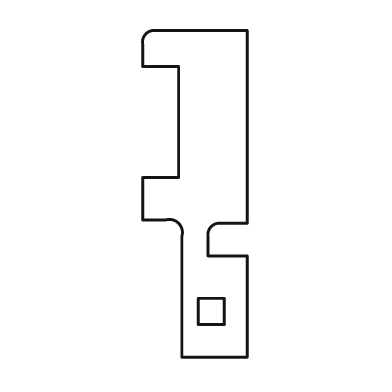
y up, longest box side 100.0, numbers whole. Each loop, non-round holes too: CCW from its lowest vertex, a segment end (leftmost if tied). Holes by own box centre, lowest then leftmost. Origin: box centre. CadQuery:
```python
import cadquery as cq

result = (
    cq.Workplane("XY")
    .moveTo(-4.0, -50.0)
    .lineTo(16.0, -50.0)
    .lineTo(16.0, -19.0)
    .lineTo(4.0, -19.0)
    .lineTo(4.0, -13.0)
    .threePointArc((5.0, -10.0), (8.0, -9.0))
    .lineTo(16.0, -9.0)
    .lineTo(16.0, 50.0)
    .lineTo(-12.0, 50.0)
    .threePointArc((-15.0, 49.0), (-16.0, 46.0))
    .lineTo(-16.0, 39.0)
    .lineTo(-5.0, 39.0)
    .lineTo(-5.0, 5.0)
    .lineTo(-16.0, 5.0)
    .lineTo(-16.0, -8.0)
    .lineTo(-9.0, -8.0)
    .threePointArc((-5.0, -9.0), (-4.0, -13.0))
    .close()
    .moveTo(1.0, -40.0)
    .lineTo(9.0, -40.0)
    .lineTo(9.0, -32.0)
    .lineTo(1.0, -32.0)
    .close()
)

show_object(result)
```